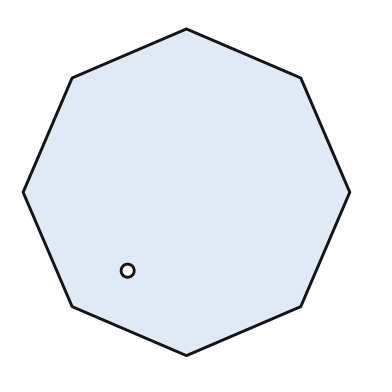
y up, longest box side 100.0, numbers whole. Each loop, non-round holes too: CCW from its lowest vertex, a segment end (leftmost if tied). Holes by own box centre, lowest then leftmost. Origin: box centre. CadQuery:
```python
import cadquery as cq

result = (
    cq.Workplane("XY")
    .moveTo(0.0, -50.0)
    .lineTo(35.0, -35.0)
    .lineTo(50.0, 0.0)
    .lineTo(35.0, 35.0)
    .lineTo(0.0, 50.0)
    .lineTo(-35.0, 35.0)
    .lineTo(-50.0, 0.0)
    .lineTo(-35.0, -35.0)
    .close()
    .moveTo(-18.0, -24.0)
    .circle(2.0)
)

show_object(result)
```